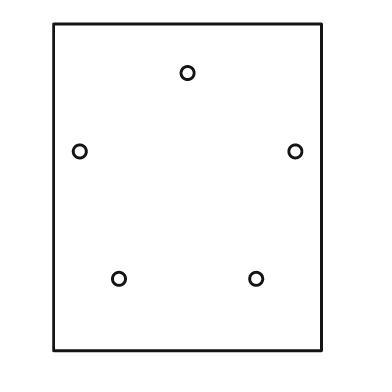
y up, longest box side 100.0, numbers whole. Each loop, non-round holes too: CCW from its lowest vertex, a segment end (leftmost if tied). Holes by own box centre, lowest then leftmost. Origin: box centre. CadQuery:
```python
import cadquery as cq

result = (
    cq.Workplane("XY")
    .moveTo(-41.0, -50.0)
    .lineTo(41.0, -50.0)
    .lineTo(41.0, 50.0)
    .lineTo(-41.0, 50.0)
    .close()
    .moveTo(-21.0, -28.0)
    .circle(2.0)
    .moveTo(21.0, -28.0)
    .circle(2.0)
    .moveTo(-33.0, 11.0)
    .circle(2.0)
    .moveTo(33.0, 11.0)
    .circle(2.0)
    .moveTo(0.0, 35.0)
    .circle(2.0)
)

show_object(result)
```